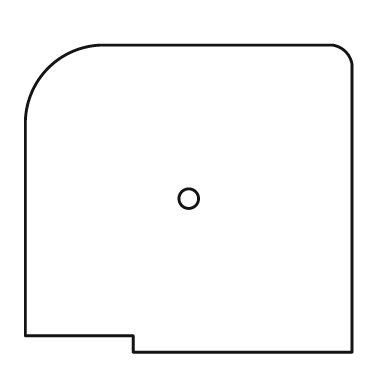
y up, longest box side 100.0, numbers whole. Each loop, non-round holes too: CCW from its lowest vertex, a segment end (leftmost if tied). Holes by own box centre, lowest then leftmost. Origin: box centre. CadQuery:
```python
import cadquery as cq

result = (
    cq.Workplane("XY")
    .moveTo(-17.0, -47.0)
    .lineTo(50.0, -47.0)
    .lineTo(50.0, 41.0)
    .threePointArc((48.0, 45.0), (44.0, 47.0))
    .lineTo(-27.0, 47.0)
    .threePointArc((-43.0, 40.0), (-50.0, 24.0))
    .lineTo(-50.0, -42.0)
    .lineTo(-17.0, -42.0)
    .close()
    .moveTo(0.0, 0.0)
    .circle(3.0)
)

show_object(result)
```